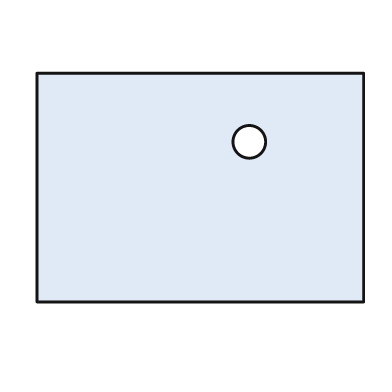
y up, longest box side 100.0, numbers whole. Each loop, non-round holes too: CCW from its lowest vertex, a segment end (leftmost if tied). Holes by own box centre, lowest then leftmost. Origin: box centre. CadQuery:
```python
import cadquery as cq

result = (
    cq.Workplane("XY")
    .moveTo(-50.0, -35.0)
    .lineTo(50.0, -35.0)
    .lineTo(50.0, 35.0)
    .lineTo(-50.0, 35.0)
    .close()
    .moveTo(15.0, 14.0)
    .circle(5.0)
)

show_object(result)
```